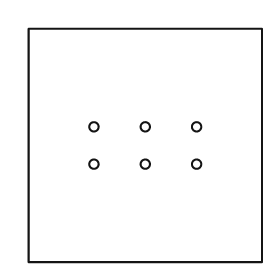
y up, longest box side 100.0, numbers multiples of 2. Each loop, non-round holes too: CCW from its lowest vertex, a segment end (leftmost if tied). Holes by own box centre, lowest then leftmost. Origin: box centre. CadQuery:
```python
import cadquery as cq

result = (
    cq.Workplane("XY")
    .moveTo(-50.0, -50.0)
    .lineTo(50.0, -50.0)
    .lineTo(50.0, 50.0)
    .lineTo(-50.0, 50.0)
    .close()
    .moveTo(-22.0, -8.0)
    .circle(2.0)
    .moveTo(0.0, -8.0)
    .circle(2.0)
    .moveTo(22.0, -8.0)
    .circle(2.0)
    .moveTo(-22.0, 8.0)
    .circle(2.0)
    .moveTo(0.0, 8.0)
    .circle(2.0)
    .moveTo(22.0, 8.0)
    .circle(2.0)
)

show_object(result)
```